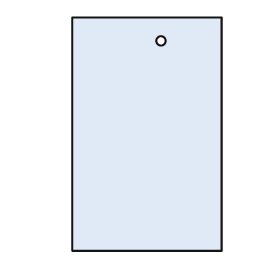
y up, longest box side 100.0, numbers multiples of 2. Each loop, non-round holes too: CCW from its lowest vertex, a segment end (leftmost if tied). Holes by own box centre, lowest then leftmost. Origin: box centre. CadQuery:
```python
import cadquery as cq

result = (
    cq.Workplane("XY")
    .moveTo(-32.0, -50.0)
    .lineTo(32.0, -50.0)
    .lineTo(32.0, 50.0)
    .lineTo(-32.0, 50.0)
    .close()
    .moveTo(6.0, 40.0)
    .circle(2.0)
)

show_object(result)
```